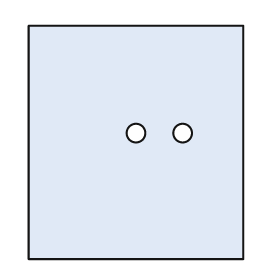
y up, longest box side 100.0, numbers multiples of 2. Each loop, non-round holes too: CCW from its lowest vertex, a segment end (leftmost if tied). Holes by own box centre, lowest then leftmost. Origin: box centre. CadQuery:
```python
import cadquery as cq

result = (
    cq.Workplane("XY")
    .moveTo(-46.0, -50.0)
    .lineTo(46.0, -50.0)
    .lineTo(46.0, 50.0)
    .lineTo(-46.0, 50.0)
    .close()
    .moveTo(0.0, 4.0)
    .circle(4.0)
    .moveTo(20.0, 4.0)
    .circle(4.0)
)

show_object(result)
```